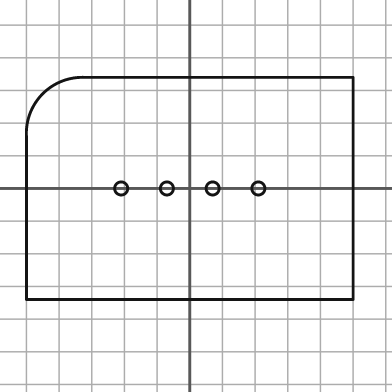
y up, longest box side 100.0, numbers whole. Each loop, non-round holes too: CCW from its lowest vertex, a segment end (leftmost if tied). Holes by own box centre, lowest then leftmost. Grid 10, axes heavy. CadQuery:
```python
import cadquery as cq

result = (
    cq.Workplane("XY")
    .moveTo(-50.0, -34.0)
    .lineTo(50.0, -34.0)
    .lineTo(50.0, 34.0)
    .lineTo(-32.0, 34.0)
    .threePointArc((-45.0, 29.0), (-50.0, 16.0))
    .close()
    .moveTo(-21.0, 0.0)
    .circle(2.0)
    .moveTo(-7.0, 0.0)
    .circle(2.0)
    .moveTo(7.0, 0.0)
    .circle(2.0)
    .moveTo(21.0, 0.0)
    .circle(2.0)
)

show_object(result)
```